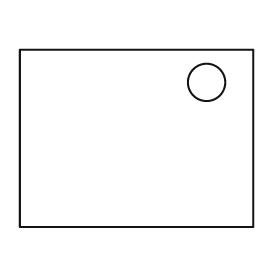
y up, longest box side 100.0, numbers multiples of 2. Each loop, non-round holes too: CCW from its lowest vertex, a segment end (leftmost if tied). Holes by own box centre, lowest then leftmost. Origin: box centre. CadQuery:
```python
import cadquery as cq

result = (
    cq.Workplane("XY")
    .moveTo(-50.0, -38.0)
    .lineTo(50.0, -38.0)
    .lineTo(50.0, 38.0)
    .lineTo(-50.0, 38.0)
    .close()
    .moveTo(30.0, 24.0)
    .circle(8.0)
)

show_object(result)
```